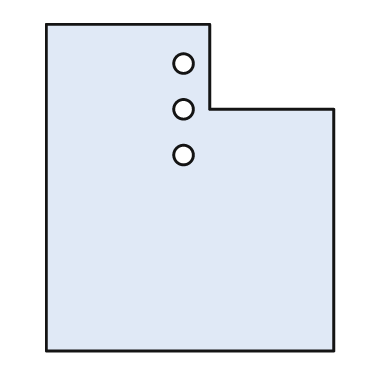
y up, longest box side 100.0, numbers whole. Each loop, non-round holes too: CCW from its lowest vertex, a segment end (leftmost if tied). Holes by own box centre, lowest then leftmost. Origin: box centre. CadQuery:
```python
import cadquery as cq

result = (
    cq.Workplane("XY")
    .moveTo(-44.0, -50.0)
    .lineTo(44.0, -50.0)
    .lineTo(44.0, 24.0)
    .lineTo(6.0, 24.0)
    .lineTo(6.0, 50.0)
    .lineTo(-44.0, 50.0)
    .close()
    .moveTo(-2.0, 10.0)
    .circle(3.0)
    .moveTo(-2.0, 24.0)
    .circle(3.0)
    .moveTo(-2.0, 38.0)
    .circle(3.0)
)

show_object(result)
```